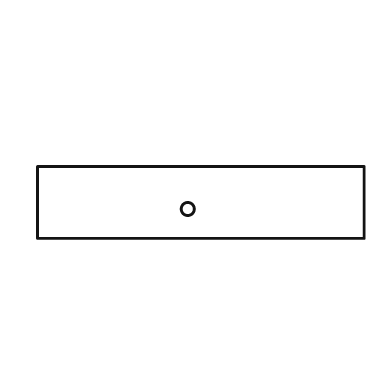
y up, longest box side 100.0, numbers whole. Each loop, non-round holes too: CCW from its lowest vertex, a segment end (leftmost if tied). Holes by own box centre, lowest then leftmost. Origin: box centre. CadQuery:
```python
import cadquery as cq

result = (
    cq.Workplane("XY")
    .moveTo(-50.0, -11.0)
    .lineTo(50.0, -11.0)
    .lineTo(50.0, 11.0)
    .lineTo(-50.0, 11.0)
    .close()
    .moveTo(-4.0, -2.0)
    .circle(2.0)
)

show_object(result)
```